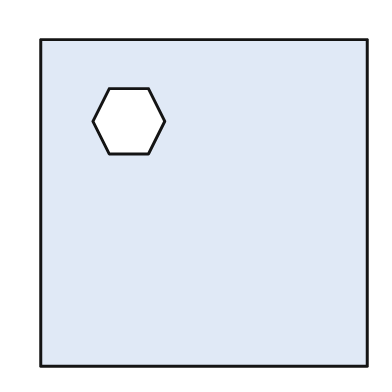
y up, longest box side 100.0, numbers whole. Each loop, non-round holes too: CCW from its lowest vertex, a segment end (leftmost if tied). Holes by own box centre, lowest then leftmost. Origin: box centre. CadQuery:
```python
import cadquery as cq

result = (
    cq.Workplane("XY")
    .moveTo(-50.0, -50.0)
    .lineTo(50.0, -50.0)
    .lineTo(50.0, 50.0)
    .lineTo(-50.0, 50.0)
    .close()
    .moveTo(-29.0, 15.0)
    .lineTo(-17.0, 15.0)
    .lineTo(-12.0, 25.0)
    .lineTo(-17.0, 35.0)
    .lineTo(-29.0, 35.0)
    .lineTo(-34.0, 25.0)
    .close()
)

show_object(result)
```